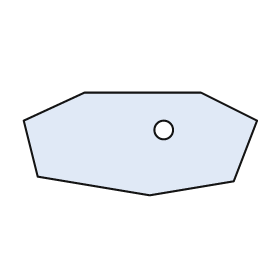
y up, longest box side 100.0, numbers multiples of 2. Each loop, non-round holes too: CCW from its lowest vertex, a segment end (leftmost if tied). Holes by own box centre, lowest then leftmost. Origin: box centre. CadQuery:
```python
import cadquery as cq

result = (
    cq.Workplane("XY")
    .moveTo(4.0, -22.0)
    .lineTo(40.0, -16.0)
    .lineTo(50.0, 10.0)
    .lineTo(26.0, 22.0)
    .lineTo(-24.0, 22.0)
    .lineTo(-50.0, 10.0)
    .lineTo(-44.0, -14.0)
    .close()
    .moveTo(10.0, 6.0)
    .circle(4.0)
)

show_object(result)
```